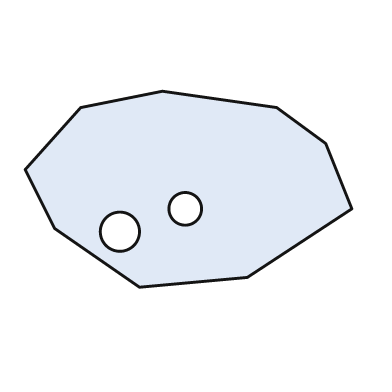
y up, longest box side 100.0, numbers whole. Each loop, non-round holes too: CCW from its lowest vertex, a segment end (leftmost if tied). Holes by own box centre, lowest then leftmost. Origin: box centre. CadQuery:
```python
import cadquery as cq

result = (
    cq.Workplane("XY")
    .moveTo(-15.0, -30.0)
    .lineTo(18.0, -27.0)
    .lineTo(50.0, -6.0)
    .lineTo(42.0, 14.0)
    .lineTo(27.0, 25.0)
    .lineTo(-8.0, 30.0)
    .lineTo(-33.0, 25.0)
    .lineTo(-50.0, 6.0)
    .lineTo(-41.0, -12.0)
    .close()
    .moveTo(-21.0, -13.0)
    .circle(6.0)
    .moveTo(-1.0, -6.0)
    .circle(5.0)
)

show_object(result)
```